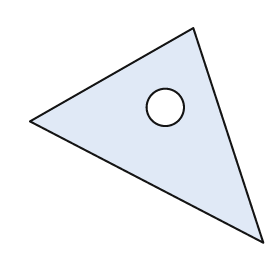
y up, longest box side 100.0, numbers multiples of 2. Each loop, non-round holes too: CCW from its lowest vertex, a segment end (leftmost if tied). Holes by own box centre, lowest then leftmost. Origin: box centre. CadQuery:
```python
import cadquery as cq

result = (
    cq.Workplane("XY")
    .moveTo(50.0, -46.0)
    .lineTo(20.0, 46.0)
    .lineTo(-50.0, 6.0)
    .close()
    .moveTo(8.0, 12.0)
    .circle(8.0)
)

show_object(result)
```